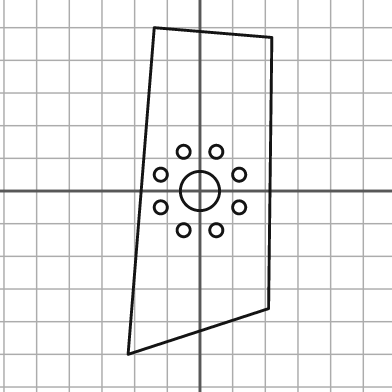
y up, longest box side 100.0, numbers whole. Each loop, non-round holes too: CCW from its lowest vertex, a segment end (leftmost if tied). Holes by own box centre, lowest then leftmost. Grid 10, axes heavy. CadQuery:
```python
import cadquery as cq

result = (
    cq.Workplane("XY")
    .moveTo(-22.0, -50.0)
    .lineTo(21.0, -36.0)
    .lineTo(22.0, 47.0)
    .lineTo(-14.0, 50.0)
    .close()
    .moveTo(-5.0, -12.0)
    .circle(2.0)
    .moveTo(5.0, -12.0)
    .circle(2.0)
    .moveTo(-12.0, -5.0)
    .circle(2.0)
    .moveTo(12.0, -5.0)
    .circle(2.0)
    .moveTo(0.0, 0.0)
    .circle(6.0)
    .moveTo(-12.0, 5.0)
    .circle(2.0)
    .moveTo(12.0, 5.0)
    .circle(2.0)
    .moveTo(-5.0, 12.0)
    .circle(2.0)
    .moveTo(5.0, 12.0)
    .circle(2.0)
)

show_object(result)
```